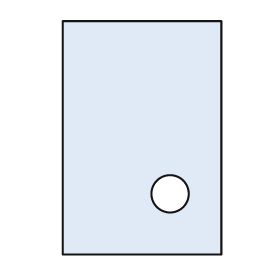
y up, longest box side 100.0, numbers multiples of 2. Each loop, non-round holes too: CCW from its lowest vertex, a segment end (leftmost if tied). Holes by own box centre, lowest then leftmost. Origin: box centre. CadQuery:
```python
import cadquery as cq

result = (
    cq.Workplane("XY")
    .moveTo(-34.0, -50.0)
    .lineTo(34.0, -50.0)
    .lineTo(34.0, 50.0)
    .lineTo(-34.0, 50.0)
    .close()
    .moveTo(12.0, -24.0)
    .circle(8.0)
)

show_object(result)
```